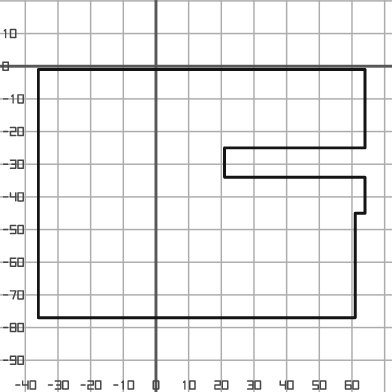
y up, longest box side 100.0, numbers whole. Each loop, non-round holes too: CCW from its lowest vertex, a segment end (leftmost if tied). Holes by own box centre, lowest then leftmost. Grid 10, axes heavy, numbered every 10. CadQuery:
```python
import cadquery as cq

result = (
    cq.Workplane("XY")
    .moveTo(-36.0, -77.0)
    .lineTo(61.0, -77.0)
    .lineTo(61.0, -45.0)
    .lineTo(64.0, -45.0)
    .lineTo(64.0, -34.0)
    .lineTo(21.0, -34.0)
    .lineTo(21.0, -25.0)
    .lineTo(64.0, -25.0)
    .lineTo(64.0, -1.0)
    .lineTo(-36.0, -1.0)
    .close()
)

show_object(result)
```